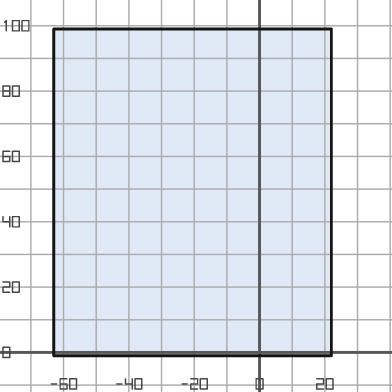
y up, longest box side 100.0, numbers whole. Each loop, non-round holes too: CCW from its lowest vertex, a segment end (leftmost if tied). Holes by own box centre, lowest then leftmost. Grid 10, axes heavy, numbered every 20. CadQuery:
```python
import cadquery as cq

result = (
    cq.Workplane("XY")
    .moveTo(-63.0, -1.0)
    .lineTo(22.0, -1.0)
    .lineTo(22.0, 99.0)
    .lineTo(-63.0, 99.0)
    .close()
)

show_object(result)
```